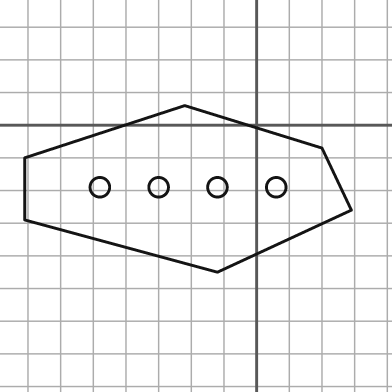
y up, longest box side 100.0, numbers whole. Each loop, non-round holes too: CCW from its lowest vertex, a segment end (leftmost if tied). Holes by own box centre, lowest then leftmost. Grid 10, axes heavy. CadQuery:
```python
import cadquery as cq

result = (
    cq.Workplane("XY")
    .moveTo(-12.0, -45.0)
    .lineTo(29.0, -26.0)
    .lineTo(20.0, -7.0)
    .lineTo(-22.0, 6.0)
    .lineTo(-71.0, -10.0)
    .lineTo(-71.0, -29.0)
    .close()
    .moveTo(-48.0, -19.0)
    .circle(3.0)
    .moveTo(-30.0, -19.0)
    .circle(3.0)
    .moveTo(-12.0, -19.0)
    .circle(3.0)
    .moveTo(6.0, -19.0)
    .circle(3.0)
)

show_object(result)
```